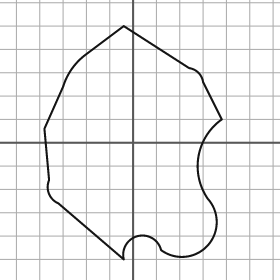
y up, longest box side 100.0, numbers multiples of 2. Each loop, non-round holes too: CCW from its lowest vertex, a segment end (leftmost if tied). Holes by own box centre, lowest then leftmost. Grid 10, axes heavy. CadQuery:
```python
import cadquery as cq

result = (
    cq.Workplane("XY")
    .moveTo(-4.0, -50.0)
    .threePointArc((2.0, -40.0), (12.0, -46.0))
    .threePointArc((32.0, -44.0), (32.0, -24.0))
    .threePointArc((28.0, -6.0), (38.0, 10.0))
    .lineTo(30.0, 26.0)
    .threePointArc((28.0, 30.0), (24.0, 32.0))
    .lineTo(-4.0, 50.0)
    .lineTo(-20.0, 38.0)
    .threePointArc((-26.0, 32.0), (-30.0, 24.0))
    .lineTo(-38.0, 6.0)
    .lineTo(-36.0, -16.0)
    .threePointArc((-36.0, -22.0), (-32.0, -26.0))
    .close()
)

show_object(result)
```